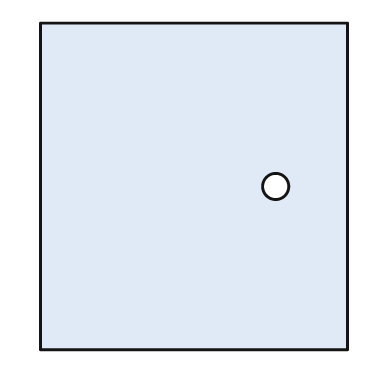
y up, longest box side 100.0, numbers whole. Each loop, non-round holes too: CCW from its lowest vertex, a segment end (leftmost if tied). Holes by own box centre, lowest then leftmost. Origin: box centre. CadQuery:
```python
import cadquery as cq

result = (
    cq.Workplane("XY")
    .moveTo(-47.0, -50.0)
    .lineTo(47.0, -50.0)
    .lineTo(47.0, 50.0)
    .lineTo(-47.0, 50.0)
    .close()
    .moveTo(25.0, 0.0)
    .circle(4.0)
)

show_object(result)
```